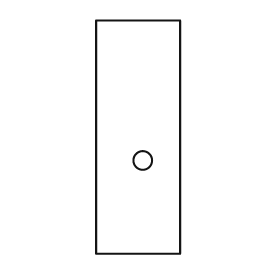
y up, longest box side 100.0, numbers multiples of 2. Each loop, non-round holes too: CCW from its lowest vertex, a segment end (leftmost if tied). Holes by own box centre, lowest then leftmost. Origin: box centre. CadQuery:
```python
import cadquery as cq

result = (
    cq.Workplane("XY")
    .moveTo(-18.0, -50.0)
    .lineTo(18.0, -50.0)
    .lineTo(18.0, 50.0)
    .lineTo(-18.0, 50.0)
    .close()
    .moveTo(2.0, -10.0)
    .circle(4.0)
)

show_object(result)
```